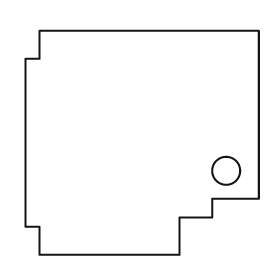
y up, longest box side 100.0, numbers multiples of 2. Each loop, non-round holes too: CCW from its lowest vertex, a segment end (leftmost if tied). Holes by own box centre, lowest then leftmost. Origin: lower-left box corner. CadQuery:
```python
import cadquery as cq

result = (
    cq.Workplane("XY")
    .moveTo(6.0, 0.0)
    .lineTo(66.0, 0.0)
    .lineTo(66.0, 16.0)
    .lineTo(80.0, 16.0)
    .lineTo(80.0, 24.0)
    .lineTo(100.0, 24.0)
    .lineTo(100.0, 96.0)
    .lineTo(6.0, 96.0)
    .lineTo(6.0, 84.0)
    .lineTo(0.0, 84.0)
    .lineTo(0.0, 12.0)
    .lineTo(6.0, 12.0)
    .close()
    .moveTo(86.0, 36.0)
    .circle(6.0)
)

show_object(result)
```